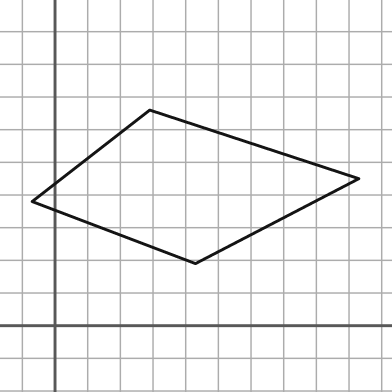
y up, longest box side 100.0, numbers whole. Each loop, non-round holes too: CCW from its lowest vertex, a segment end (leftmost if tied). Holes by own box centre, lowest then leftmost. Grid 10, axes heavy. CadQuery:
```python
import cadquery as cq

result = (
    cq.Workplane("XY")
    .moveTo(43.0, 19.0)
    .lineTo(93.0, 45.0)
    .lineTo(29.0, 66.0)
    .lineTo(-7.0, 38.0)
    .close()
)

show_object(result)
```